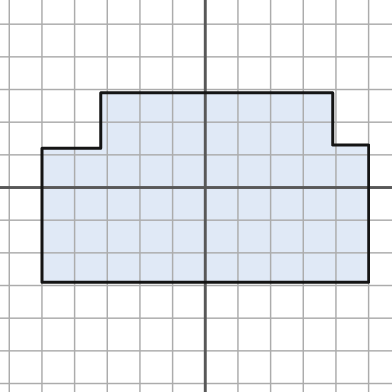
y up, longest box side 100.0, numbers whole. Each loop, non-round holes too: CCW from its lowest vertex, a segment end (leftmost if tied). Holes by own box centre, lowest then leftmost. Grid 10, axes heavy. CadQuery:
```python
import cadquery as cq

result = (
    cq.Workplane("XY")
    .moveTo(-50.0, -29.0)
    .lineTo(50.0, -29.0)
    .lineTo(50.0, 13.0)
    .lineTo(39.0, 13.0)
    .lineTo(39.0, 29.0)
    .lineTo(-32.0, 29.0)
    .lineTo(-32.0, 12.0)
    .lineTo(-50.0, 12.0)
    .close()
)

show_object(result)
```